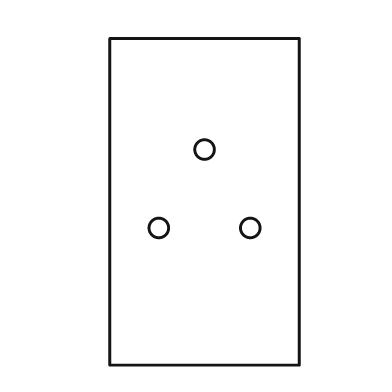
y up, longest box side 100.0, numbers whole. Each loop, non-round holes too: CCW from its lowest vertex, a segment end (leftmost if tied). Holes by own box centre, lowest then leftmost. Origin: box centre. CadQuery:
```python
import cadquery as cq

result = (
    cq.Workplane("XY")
    .moveTo(-29.0, -50.0)
    .lineTo(29.0, -50.0)
    .lineTo(29.0, 50.0)
    .lineTo(-29.0, 50.0)
    .close()
    .moveTo(-14.0, -8.0)
    .circle(3.0)
    .moveTo(14.0, -8.0)
    .circle(3.0)
    .moveTo(0.0, 16.0)
    .circle(3.0)
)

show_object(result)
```